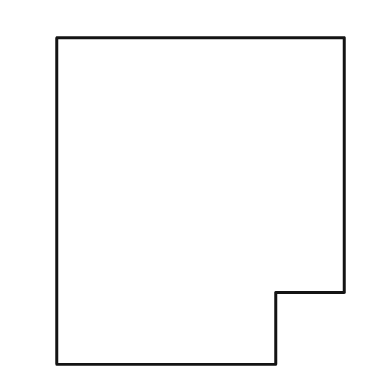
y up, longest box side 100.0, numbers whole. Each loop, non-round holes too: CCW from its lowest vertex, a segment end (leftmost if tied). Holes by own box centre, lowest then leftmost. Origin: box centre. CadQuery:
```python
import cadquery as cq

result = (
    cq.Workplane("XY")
    .moveTo(-44.0, -50.0)
    .lineTo(23.0, -50.0)
    .lineTo(23.0, -28.0)
    .lineTo(44.0, -28.0)
    .lineTo(44.0, 50.0)
    .lineTo(-44.0, 50.0)
    .close()
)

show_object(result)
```